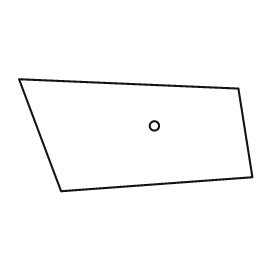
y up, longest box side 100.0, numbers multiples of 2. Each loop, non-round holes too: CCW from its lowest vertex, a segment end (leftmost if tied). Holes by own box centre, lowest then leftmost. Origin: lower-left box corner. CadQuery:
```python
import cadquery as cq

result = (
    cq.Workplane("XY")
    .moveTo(18.0, 0.0)
    .lineTo(100.0, 6.0)
    .lineTo(94.0, 44.0)
    .lineTo(0.0, 48.0)
    .close()
    .moveTo(58.0, 28.0)
    .circle(2.0)
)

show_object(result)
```